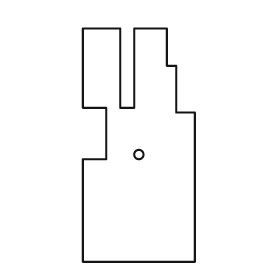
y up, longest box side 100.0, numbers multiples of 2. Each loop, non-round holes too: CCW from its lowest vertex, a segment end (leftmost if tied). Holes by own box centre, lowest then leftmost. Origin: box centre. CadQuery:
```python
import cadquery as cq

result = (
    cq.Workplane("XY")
    .moveTo(-24.0, -50.0)
    .lineTo(24.0, -50.0)
    .lineTo(24.0, 14.0)
    .lineTo(16.0, 14.0)
    .lineTo(16.0, 34.0)
    .lineTo(12.0, 34.0)
    .lineTo(12.0, 50.0)
    .lineTo(-2.0, 50.0)
    .lineTo(-2.0, 16.0)
    .lineTo(-8.0, 16.0)
    .lineTo(-8.0, 50.0)
    .lineTo(-24.0, 50.0)
    .lineTo(-24.0, 16.0)
    .lineTo(-14.0, 16.0)
    .lineTo(-14.0, -6.0)
    .lineTo(-24.0, -6.0)
    .close()
    .moveTo(0.0, -4.0)
    .circle(2.0)
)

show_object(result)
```